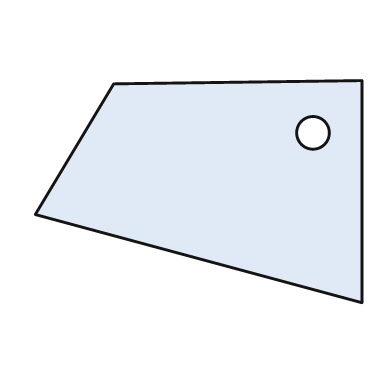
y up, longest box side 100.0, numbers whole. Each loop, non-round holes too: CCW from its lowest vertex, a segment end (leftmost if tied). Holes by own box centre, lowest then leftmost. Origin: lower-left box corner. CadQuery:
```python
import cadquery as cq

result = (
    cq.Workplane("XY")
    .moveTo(100.0, 0.0)
    .lineTo(100.0, 68.0)
    .lineTo(24.0, 67.0)
    .lineTo(0.0, 27.0)
    .close()
    .moveTo(85.0, 52.0)
    .circle(5.0)
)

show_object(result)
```